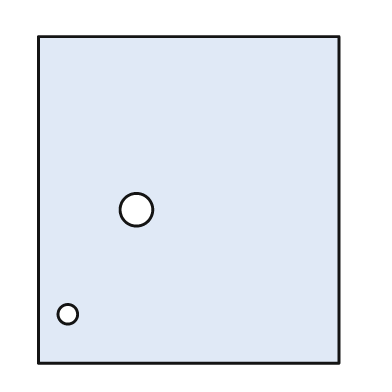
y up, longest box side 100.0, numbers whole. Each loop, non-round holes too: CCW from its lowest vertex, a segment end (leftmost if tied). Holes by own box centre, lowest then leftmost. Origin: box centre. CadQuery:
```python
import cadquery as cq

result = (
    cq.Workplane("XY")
    .moveTo(-46.0, -50.0)
    .lineTo(46.0, -50.0)
    .lineTo(46.0, 50.0)
    .lineTo(-46.0, 50.0)
    .close()
    .moveTo(-37.0, -35.0)
    .circle(3.0)
    .moveTo(-16.0, -3.0)
    .circle(5.0)
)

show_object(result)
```